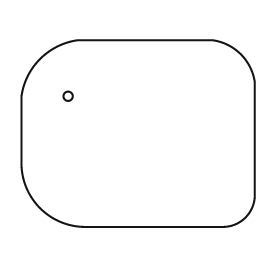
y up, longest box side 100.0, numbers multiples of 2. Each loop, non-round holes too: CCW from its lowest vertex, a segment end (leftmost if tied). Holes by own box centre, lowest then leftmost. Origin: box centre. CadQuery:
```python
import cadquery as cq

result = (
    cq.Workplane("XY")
    .moveTo(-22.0, -40.0)
    .lineTo(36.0, -40.0)
    .threePointArc((46.0, -36.0), (50.0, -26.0))
    .lineTo(50.0, 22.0)
    .threePointArc((44.0, 34.0), (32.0, 40.0))
    .lineTo(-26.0, 40.0)
    .threePointArc((-42.0, 32.0), (-50.0, 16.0))
    .lineTo(-50.0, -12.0)
    .threePointArc((-42.0, -32.0), (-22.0, -40.0))
    .close()
    .moveTo(-30.0, 16.0)
    .circle(2.0)
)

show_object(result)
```